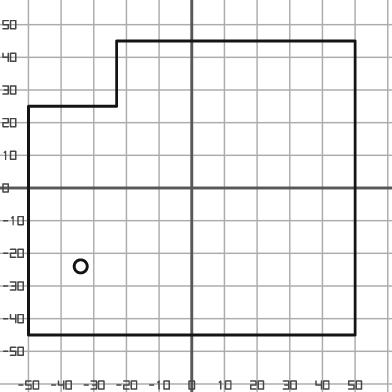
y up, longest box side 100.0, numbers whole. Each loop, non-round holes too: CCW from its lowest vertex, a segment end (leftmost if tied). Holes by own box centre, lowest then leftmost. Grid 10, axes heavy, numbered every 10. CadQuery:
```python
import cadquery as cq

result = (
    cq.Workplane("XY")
    .moveTo(-50.0, -45.0)
    .lineTo(50.0, -45.0)
    .lineTo(50.0, 45.0)
    .lineTo(-23.0, 45.0)
    .lineTo(-23.0, 25.0)
    .lineTo(-50.0, 25.0)
    .close()
    .moveTo(-34.0, -24.0)
    .circle(2.0)
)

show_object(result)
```